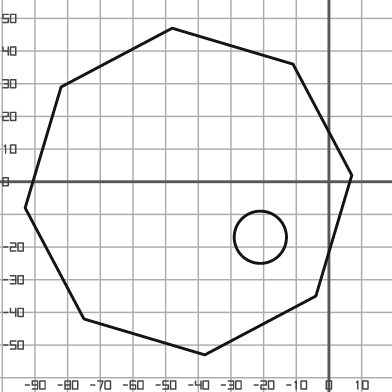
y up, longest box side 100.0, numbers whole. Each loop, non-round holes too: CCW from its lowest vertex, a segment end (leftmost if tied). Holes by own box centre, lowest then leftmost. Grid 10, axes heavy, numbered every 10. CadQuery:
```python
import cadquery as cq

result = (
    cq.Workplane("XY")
    .moveTo(-38.0, -53.0)
    .lineTo(-4.0, -35.0)
    .lineTo(7.0, 2.0)
    .lineTo(-11.0, 36.0)
    .lineTo(-48.0, 47.0)
    .lineTo(-82.0, 29.0)
    .lineTo(-93.0, -8.0)
    .lineTo(-75.0, -42.0)
    .close()
    .moveTo(-21.0, -17.0)
    .circle(8.0)
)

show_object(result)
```